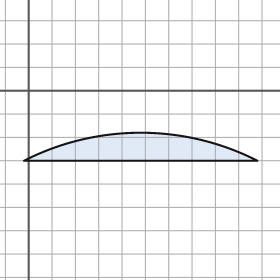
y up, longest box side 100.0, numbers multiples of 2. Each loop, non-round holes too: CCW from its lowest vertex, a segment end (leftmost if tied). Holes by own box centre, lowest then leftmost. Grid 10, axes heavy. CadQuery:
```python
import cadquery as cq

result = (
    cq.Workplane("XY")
    .moveTo(-2.0, -30.0)
    .lineTo(98.0, -30.0)
    .threePointArc((48.0, -18.0), (-2.0, -30.0))
    .close()
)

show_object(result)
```